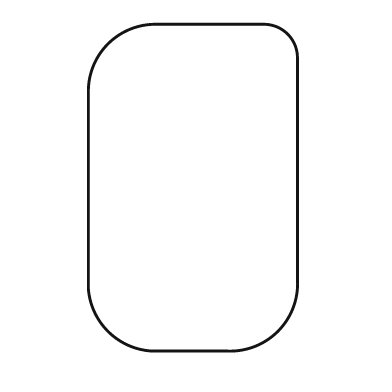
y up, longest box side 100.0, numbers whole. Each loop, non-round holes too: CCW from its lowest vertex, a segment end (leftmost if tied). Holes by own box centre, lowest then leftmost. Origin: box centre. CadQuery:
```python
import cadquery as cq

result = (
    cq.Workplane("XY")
    .moveTo(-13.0, -50.0)
    .lineTo(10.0, -50.0)
    .threePointArc((26.0, -44.0), (32.0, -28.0))
    .lineTo(32.0, 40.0)
    .threePointArc((29.0, 47.0), (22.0, 50.0))
    .lineTo(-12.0, 50.0)
    .threePointArc((-26.0, 44.0), (-32.0, 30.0))
    .lineTo(-32.0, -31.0)
    .threePointArc((-26.0, -44.0), (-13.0, -50.0))
    .close()
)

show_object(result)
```